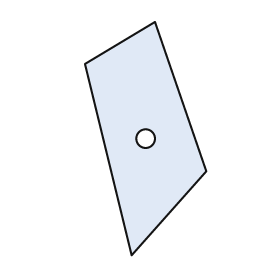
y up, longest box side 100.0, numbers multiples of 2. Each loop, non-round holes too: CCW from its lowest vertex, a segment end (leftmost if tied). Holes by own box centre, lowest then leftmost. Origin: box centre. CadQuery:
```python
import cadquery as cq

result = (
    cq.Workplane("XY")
    .moveTo(-6.0, -50.0)
    .lineTo(26.0, -14.0)
    .lineTo(4.0, 50.0)
    .lineTo(-26.0, 32.0)
    .close()
    .moveTo(0.0, 0.0)
    .circle(4.0)
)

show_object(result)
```